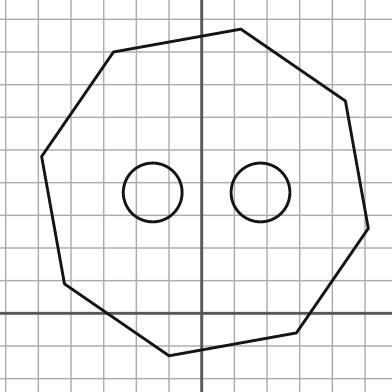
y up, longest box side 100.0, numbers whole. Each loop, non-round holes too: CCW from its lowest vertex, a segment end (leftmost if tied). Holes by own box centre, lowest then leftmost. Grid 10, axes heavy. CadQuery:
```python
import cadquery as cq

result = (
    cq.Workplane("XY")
    .moveTo(-10.0, -13.0)
    .lineTo(29.0, -6.0)
    .lineTo(51.0, 26.0)
    .lineTo(44.0, 65.0)
    .lineTo(12.0, 87.0)
    .lineTo(-27.0, 80.0)
    .lineTo(-49.0, 48.0)
    .lineTo(-42.0, 9.0)
    .close()
    .moveTo(-15.0, 37.0)
    .circle(9.0)
    .moveTo(18.0, 37.0)
    .circle(9.0)
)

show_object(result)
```